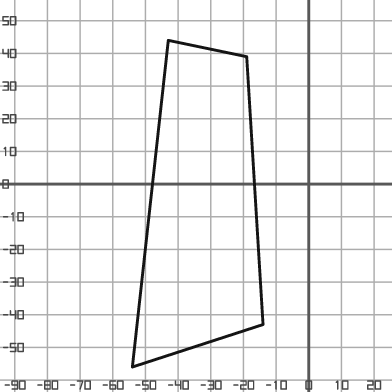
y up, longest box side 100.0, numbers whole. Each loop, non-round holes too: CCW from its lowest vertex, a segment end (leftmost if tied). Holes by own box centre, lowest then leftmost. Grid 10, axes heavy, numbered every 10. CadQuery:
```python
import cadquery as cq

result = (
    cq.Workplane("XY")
    .moveTo(-54.0, -56.0)
    .lineTo(-14.0, -43.0)
    .lineTo(-19.0, 39.0)
    .lineTo(-43.0, 44.0)
    .close()
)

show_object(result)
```